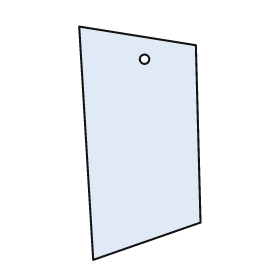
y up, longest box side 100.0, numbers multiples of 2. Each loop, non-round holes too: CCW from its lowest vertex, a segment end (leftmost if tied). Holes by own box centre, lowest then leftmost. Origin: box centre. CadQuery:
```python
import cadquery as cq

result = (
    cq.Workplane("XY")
    .moveTo(-20.0, -50.0)
    .lineTo(26.0, -34.0)
    .lineTo(24.0, 42.0)
    .lineTo(-26.0, 50.0)
    .close()
    .moveTo(2.0, 36.0)
    .circle(2.0)
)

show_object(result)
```